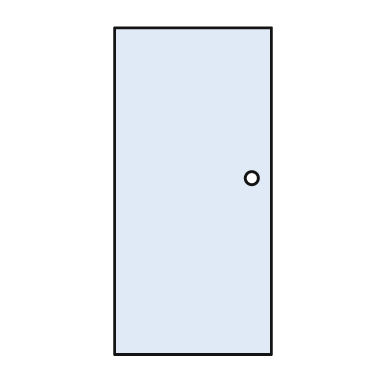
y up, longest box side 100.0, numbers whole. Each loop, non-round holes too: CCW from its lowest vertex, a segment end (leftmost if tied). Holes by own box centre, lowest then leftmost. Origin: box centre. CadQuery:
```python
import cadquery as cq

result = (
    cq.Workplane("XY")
    .moveTo(-24.0, -50.0)
    .lineTo(24.0, -50.0)
    .lineTo(24.0, 50.0)
    .lineTo(-24.0, 50.0)
    .close()
    .moveTo(18.0, 4.0)
    .circle(2.0)
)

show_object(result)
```